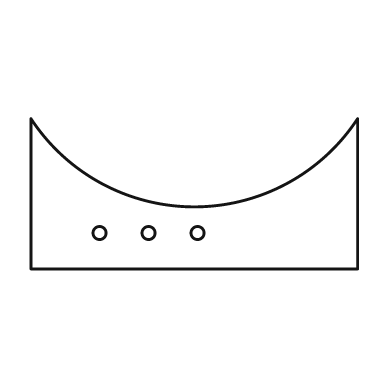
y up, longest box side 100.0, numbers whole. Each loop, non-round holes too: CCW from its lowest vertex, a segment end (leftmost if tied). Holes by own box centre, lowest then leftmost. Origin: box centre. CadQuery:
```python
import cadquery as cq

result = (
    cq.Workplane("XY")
    .moveTo(-50.0, -23.0)
    .lineTo(50.0, -23.0)
    .lineTo(50.0, 23.0)
    .threePointArc((0.0, -4.0), (-50.0, 23.0))
    .close()
    .moveTo(-29.0, -12.0)
    .circle(2.0)
    .moveTo(-14.0, -12.0)
    .circle(2.0)
    .moveTo(1.0, -12.0)
    .circle(2.0)
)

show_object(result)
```